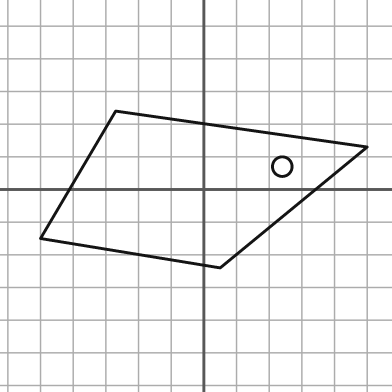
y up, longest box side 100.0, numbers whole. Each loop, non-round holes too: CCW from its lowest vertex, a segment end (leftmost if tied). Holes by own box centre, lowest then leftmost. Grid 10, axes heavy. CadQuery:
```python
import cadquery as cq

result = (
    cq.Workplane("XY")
    .moveTo(5.0, -24.0)
    .lineTo(50.0, 13.0)
    .lineTo(-27.0, 24.0)
    .lineTo(-50.0, -15.0)
    .close()
    .moveTo(24.0, 7.0)
    .circle(3.0)
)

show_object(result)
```